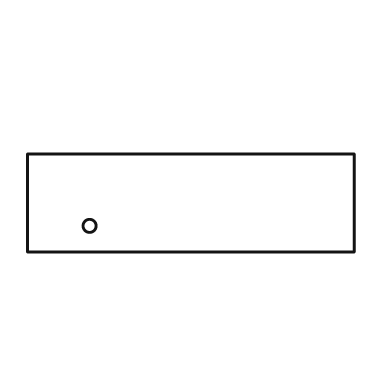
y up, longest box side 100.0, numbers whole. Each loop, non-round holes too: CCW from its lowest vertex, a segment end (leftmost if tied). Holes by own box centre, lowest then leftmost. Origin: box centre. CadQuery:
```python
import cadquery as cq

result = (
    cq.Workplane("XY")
    .moveTo(-50.0, -15.0)
    .lineTo(50.0, -15.0)
    .lineTo(50.0, 15.0)
    .lineTo(-50.0, 15.0)
    .close()
    .moveTo(-31.0, -7.0)
    .circle(2.0)
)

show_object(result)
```